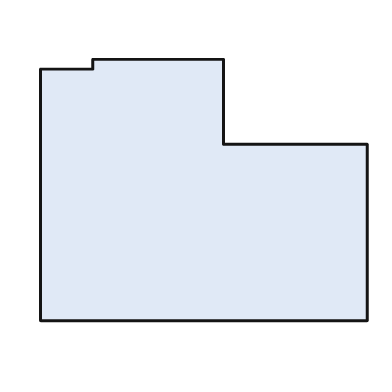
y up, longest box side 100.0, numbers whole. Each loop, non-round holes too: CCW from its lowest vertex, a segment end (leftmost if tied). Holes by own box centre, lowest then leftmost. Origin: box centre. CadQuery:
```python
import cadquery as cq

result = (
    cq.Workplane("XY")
    .moveTo(-50.0, -40.0)
    .lineTo(50.0, -40.0)
    .lineTo(50.0, 14.0)
    .lineTo(6.0, 14.0)
    .lineTo(6.0, 40.0)
    .lineTo(-34.0, 40.0)
    .lineTo(-34.0, 37.0)
    .lineTo(-50.0, 37.0)
    .close()
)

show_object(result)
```